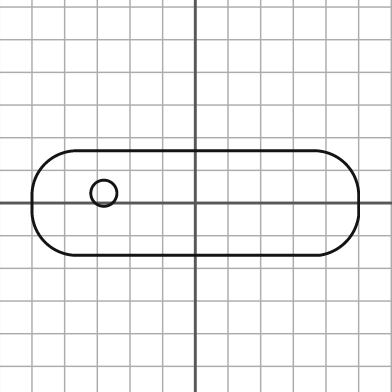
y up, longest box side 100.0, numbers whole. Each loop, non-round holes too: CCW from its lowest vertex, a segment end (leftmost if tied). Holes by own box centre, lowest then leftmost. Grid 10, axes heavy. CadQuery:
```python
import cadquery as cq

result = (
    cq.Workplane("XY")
    .moveTo(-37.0, -16.0)
    .lineTo(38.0, -16.0)
    .threePointArc((46.0, -12.0), (50.0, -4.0))
    .lineTo(50.0, 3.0)
    .threePointArc((46.0, 12.0), (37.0, 16.0))
    .lineTo(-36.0, 16.0)
    .threePointArc((-46.0, 12.0), (-50.0, 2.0))
    .lineTo(-50.0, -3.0)
    .threePointArc((-46.0, -12.0), (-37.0, -16.0))
    .close()
    .moveTo(-28.0, 3.0)
    .circle(4.0)
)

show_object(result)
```